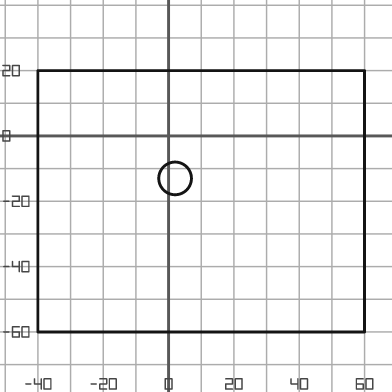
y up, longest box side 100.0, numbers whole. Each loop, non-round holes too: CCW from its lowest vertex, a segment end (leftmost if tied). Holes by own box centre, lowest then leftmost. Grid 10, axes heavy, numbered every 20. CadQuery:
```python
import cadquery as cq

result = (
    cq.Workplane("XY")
    .moveTo(-40.0, -60.0)
    .lineTo(60.0, -60.0)
    .lineTo(60.0, 20.0)
    .lineTo(-40.0, 20.0)
    .close()
    .moveTo(2.0, -13.0)
    .circle(5.0)
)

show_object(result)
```